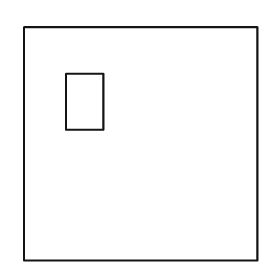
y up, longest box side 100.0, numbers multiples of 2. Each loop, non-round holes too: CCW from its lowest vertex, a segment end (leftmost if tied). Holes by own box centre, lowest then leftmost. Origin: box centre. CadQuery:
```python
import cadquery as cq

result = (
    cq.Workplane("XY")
    .moveTo(-50.0, -50.0)
    .lineTo(50.0, -50.0)
    .lineTo(50.0, 50.0)
    .lineTo(-50.0, 50.0)
    .close()
    .moveTo(-32.0, 6.0)
    .lineTo(-16.0, 6.0)
    .lineTo(-16.0, 30.0)
    .lineTo(-32.0, 30.0)
    .close()
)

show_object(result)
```